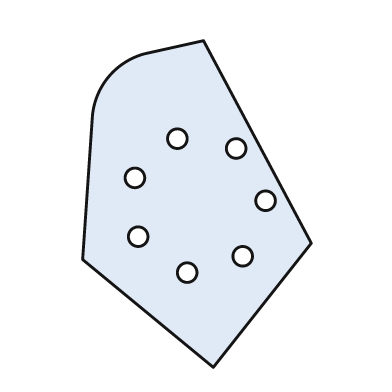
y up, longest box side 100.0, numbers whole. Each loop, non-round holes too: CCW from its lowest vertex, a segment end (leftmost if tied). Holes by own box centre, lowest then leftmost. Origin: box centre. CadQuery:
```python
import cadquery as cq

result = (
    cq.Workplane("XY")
    .moveTo(5.0, -50.0)
    .lineTo(35.0, -12.0)
    .lineTo(2.0, 50.0)
    .lineTo(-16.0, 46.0)
    .threePointArc((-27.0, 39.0), (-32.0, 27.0))
    .lineTo(-35.0, -17.0)
    .close()
    .moveTo(-3.0, -21.0)
    .circle(3.0)
    .moveTo(14.0, -16.0)
    .circle(3.0)
    .moveTo(-18.0, -10.0)
    .circle(3.0)
    .moveTo(21.0, 1.0)
    .circle(3.0)
    .moveTo(-19.0, 8.0)
    .circle(3.0)
    .moveTo(12.0, 17.0)
    .circle(3.0)
    .moveTo(-6.0, 20.0)
    .circle(3.0)
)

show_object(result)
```